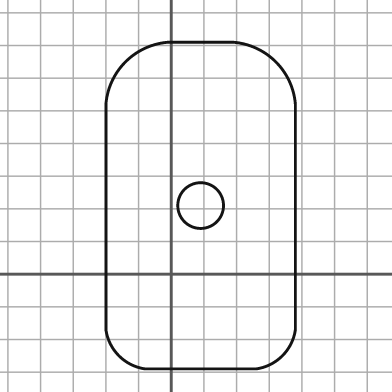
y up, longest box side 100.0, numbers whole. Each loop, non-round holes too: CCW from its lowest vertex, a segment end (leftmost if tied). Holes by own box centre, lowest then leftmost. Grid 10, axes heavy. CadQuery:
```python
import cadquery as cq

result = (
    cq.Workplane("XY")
    .moveTo(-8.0, -29.0)
    .lineTo(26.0, -29.0)
    .threePointArc((34.0, -25.0), (38.0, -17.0))
    .lineTo(38.0, 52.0)
    .threePointArc((32.0, 65.0), (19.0, 71.0))
    .lineTo(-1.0, 71.0)
    .threePointArc((-14.0, 65.0), (-20.0, 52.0))
    .lineTo(-20.0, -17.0)
    .threePointArc((-16.0, -25.0), (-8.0, -29.0))
    .close()
    .moveTo(9.0, 21.0)
    .circle(7.0)
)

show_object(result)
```